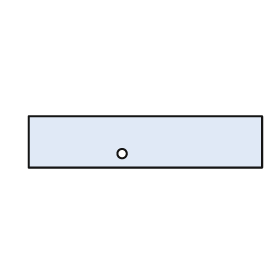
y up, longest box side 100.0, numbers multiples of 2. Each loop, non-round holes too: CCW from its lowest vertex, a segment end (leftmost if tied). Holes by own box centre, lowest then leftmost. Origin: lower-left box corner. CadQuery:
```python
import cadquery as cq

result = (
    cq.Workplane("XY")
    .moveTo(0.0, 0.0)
    .lineTo(100.0, 0.0)
    .lineTo(100.0, 22.0)
    .lineTo(0.0, 22.0)
    .close()
    .moveTo(40.0, 6.0)
    .circle(2.0)
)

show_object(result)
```